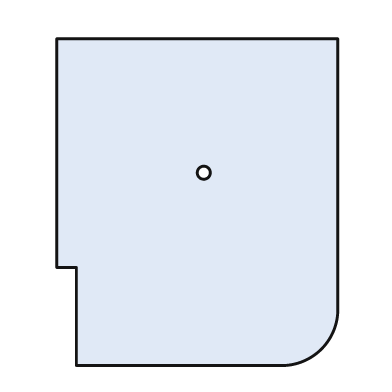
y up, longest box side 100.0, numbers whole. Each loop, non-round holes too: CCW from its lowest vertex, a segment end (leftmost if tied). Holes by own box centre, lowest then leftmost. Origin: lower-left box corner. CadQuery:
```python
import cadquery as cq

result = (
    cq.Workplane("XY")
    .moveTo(6.0, 0.0)
    .lineTo(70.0, 0.0)
    .threePointArc((81.0, 5.0), (86.0, 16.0))
    .lineTo(86.0, 100.0)
    .lineTo(0.0, 100.0)
    .lineTo(0.0, 30.0)
    .lineTo(6.0, 30.0)
    .close()
    .moveTo(45.0, 59.0)
    .circle(2.0)
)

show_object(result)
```